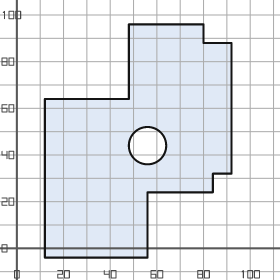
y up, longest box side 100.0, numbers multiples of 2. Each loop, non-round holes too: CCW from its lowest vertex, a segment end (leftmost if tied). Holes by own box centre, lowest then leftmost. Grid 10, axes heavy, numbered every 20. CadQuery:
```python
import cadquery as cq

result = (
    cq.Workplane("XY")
    .moveTo(12.0, -4.0)
    .lineTo(56.0, -4.0)
    .lineTo(56.0, 24.0)
    .lineTo(84.0, 24.0)
    .lineTo(84.0, 32.0)
    .lineTo(92.0, 32.0)
    .lineTo(92.0, 88.0)
    .lineTo(80.0, 88.0)
    .lineTo(80.0, 96.0)
    .lineTo(48.0, 96.0)
    .lineTo(48.0, 64.0)
    .lineTo(12.0, 64.0)
    .close()
    .moveTo(56.0, 44.0)
    .circle(8.0)
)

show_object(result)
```